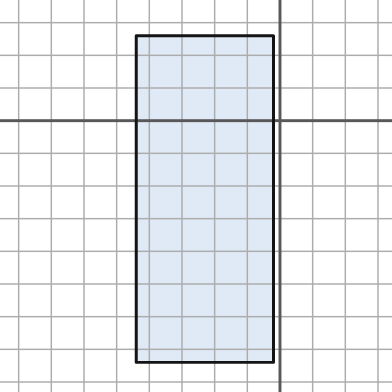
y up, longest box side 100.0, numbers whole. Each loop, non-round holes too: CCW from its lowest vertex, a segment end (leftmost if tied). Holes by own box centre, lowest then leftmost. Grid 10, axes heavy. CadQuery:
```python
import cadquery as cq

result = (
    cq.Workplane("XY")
    .moveTo(-44.0, -74.0)
    .lineTo(-2.0, -74.0)
    .lineTo(-2.0, 26.0)
    .lineTo(-44.0, 26.0)
    .close()
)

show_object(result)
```